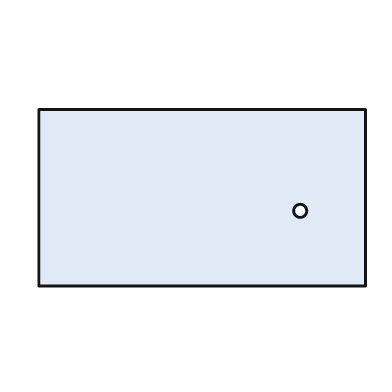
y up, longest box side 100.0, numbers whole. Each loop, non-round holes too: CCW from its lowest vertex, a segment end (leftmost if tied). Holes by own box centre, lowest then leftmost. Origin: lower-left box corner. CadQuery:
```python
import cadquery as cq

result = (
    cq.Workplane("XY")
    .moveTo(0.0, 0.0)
    .lineTo(100.0, 0.0)
    .lineTo(100.0, 54.0)
    .lineTo(0.0, 54.0)
    .close()
    .moveTo(80.0, 23.0)
    .circle(2.0)
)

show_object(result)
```